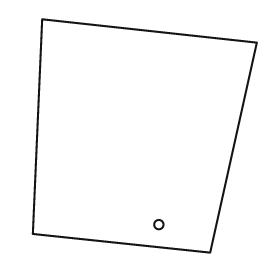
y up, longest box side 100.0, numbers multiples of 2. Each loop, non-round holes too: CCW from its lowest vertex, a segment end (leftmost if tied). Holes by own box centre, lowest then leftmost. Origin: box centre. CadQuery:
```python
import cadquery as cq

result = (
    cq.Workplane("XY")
    .moveTo(28.0, -50.0)
    .lineTo(48.0, 40.0)
    .lineTo(-44.0, 50.0)
    .lineTo(-48.0, -42.0)
    .close()
    .moveTo(6.0, -38.0)
    .circle(2.0)
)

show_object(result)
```